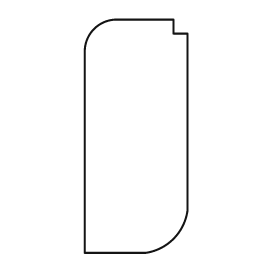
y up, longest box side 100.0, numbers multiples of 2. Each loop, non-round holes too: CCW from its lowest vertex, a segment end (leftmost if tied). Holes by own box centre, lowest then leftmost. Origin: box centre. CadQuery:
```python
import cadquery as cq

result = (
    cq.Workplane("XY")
    .moveTo(-22.0, -50.0)
    .lineTo(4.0, -50.0)
    .threePointArc((16.0, -44.0), (22.0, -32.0))
    .lineTo(22.0, 44.0)
    .lineTo(16.0, 44.0)
    .lineTo(16.0, 50.0)
    .lineTo(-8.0, 50.0)
    .threePointArc((-18.0, 46.0), (-22.0, 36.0))
    .close()
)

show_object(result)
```